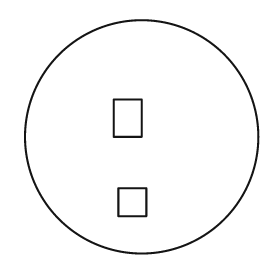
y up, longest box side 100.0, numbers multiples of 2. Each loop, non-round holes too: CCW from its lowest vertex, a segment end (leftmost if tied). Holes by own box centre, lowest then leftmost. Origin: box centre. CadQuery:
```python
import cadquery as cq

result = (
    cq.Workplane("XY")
    .moveTo(0.0, 0.0)
    .circle(50.0)
    .moveTo(-10.0, -34.0)
    .lineTo(2.0, -34.0)
    .lineTo(2.0, -22.0)
    .lineTo(-10.0, -22.0)
    .close()
    .moveTo(-12.0, 0.0)
    .lineTo(0.0, 0.0)
    .lineTo(0.0, 16.0)
    .lineTo(-12.0, 16.0)
    .close()
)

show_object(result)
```